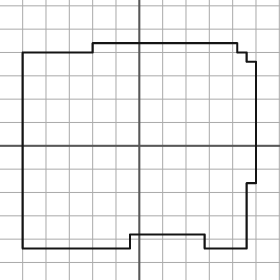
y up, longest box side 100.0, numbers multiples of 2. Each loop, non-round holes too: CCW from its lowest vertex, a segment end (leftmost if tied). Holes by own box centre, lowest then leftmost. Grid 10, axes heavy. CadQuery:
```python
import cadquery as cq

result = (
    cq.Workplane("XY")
    .moveTo(-50.0, -44.0)
    .lineTo(-4.0, -44.0)
    .lineTo(-4.0, -38.0)
    .lineTo(28.0, -38.0)
    .lineTo(28.0, -44.0)
    .lineTo(46.0, -44.0)
    .lineTo(46.0, -16.0)
    .lineTo(50.0, -16.0)
    .lineTo(50.0, 36.0)
    .lineTo(46.0, 36.0)
    .lineTo(46.0, 40.0)
    .lineTo(42.0, 40.0)
    .lineTo(42.0, 44.0)
    .lineTo(-20.0, 44.0)
    .lineTo(-20.0, 40.0)
    .lineTo(-50.0, 40.0)
    .close()
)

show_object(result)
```